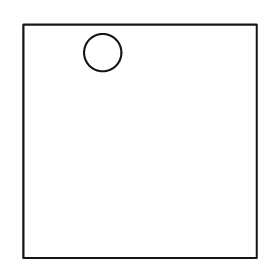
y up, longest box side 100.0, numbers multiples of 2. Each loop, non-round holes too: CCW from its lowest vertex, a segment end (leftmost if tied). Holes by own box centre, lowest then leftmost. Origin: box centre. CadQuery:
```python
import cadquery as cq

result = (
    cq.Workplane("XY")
    .moveTo(-50.0, -50.0)
    .lineTo(50.0, -50.0)
    .lineTo(50.0, 50.0)
    .lineTo(-50.0, 50.0)
    .close()
    .moveTo(-16.0, 38.0)
    .circle(8.0)
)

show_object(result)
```